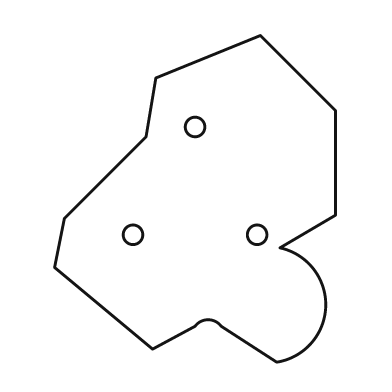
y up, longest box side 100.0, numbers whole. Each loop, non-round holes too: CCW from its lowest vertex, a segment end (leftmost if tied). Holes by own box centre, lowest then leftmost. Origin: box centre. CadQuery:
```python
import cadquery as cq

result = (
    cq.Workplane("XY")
    .moveTo(25.0, -50.0)
    .threePointArc((40.0, -33.0), (26.0, -15.0))
    .lineTo(43.0, -5.0)
    .lineTo(43.0, 27.0)
    .lineTo(20.0, 50.0)
    .lineTo(-12.0, 37.0)
    .lineTo(-15.0, 19.0)
    .lineTo(-40.0, -6.0)
    .lineTo(-43.0, -21.0)
    .lineTo(-13.0, -46.0)
    .lineTo(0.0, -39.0)
    .threePointArc((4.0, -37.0), (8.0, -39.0))
    .close()
    .moveTo(-19.0, -11.0)
    .circle(3.0)
    .moveTo(19.0, -11.0)
    .circle(3.0)
    .moveTo(0.0, 22.0)
    .circle(3.0)
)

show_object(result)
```